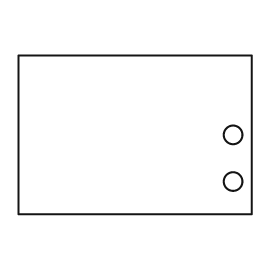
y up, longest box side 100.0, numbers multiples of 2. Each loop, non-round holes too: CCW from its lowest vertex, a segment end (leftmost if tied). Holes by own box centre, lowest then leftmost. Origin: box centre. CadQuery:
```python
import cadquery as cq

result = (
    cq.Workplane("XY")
    .moveTo(-50.0, -34.0)
    .lineTo(50.0, -34.0)
    .lineTo(50.0, 34.0)
    .lineTo(-50.0, 34.0)
    .close()
    .moveTo(42.0, -20.0)
    .circle(4.0)
    .moveTo(42.0, 0.0)
    .circle(4.0)
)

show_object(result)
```